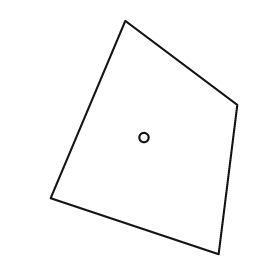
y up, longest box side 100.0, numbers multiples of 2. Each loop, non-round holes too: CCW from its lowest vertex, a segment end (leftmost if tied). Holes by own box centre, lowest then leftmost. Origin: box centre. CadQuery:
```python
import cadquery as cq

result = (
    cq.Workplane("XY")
    .moveTo(32.0, -50.0)
    .lineTo(40.0, 14.0)
    .lineTo(-8.0, 50.0)
    .lineTo(-40.0, -26.0)
    .close()
    .moveTo(0.0, 0.0)
    .circle(2.0)
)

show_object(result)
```